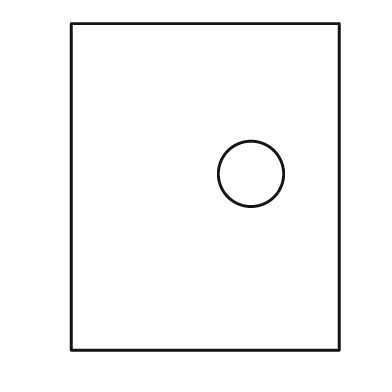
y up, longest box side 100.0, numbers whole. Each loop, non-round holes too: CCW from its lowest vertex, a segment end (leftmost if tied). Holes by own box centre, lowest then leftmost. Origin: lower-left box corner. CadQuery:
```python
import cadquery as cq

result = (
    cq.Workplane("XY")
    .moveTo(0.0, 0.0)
    .lineTo(82.0, 0.0)
    .lineTo(82.0, 100.0)
    .lineTo(0.0, 100.0)
    .close()
    .moveTo(55.0, 54.0)
    .circle(10.0)
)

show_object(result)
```